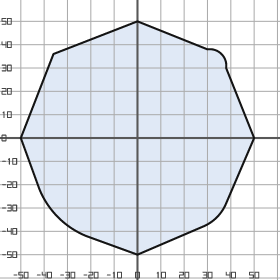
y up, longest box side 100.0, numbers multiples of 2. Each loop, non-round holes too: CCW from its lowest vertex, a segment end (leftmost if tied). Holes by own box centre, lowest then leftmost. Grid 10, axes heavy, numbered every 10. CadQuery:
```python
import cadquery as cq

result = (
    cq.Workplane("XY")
    .moveTo(0.0, -50.0)
    .lineTo(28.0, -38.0)
    .threePointArc((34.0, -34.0), (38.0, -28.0))
    .lineTo(50.0, 0.0)
    .lineTo(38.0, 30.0)
    .threePointArc((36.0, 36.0), (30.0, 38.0))
    .lineTo(0.0, 50.0)
    .lineTo(-36.0, 36.0)
    .lineTo(-50.0, 0.0)
    .lineTo(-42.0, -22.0)
    .threePointArc((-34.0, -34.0), (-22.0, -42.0))
    .close()
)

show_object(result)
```